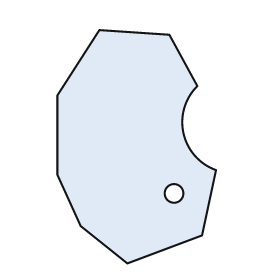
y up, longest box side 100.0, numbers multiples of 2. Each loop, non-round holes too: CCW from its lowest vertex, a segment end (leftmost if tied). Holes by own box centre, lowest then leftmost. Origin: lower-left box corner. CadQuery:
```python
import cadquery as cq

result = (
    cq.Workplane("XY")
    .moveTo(30.0, 0.0)
    .lineTo(62.0, 12.0)
    .lineTo(68.0, 40.0)
    .threePointArc((54.0, 56.0), (60.0, 76.0))
    .lineTo(48.0, 98.0)
    .lineTo(18.0, 100.0)
    .lineTo(0.0, 72.0)
    .lineTo(0.0, 38.0)
    .lineTo(10.0, 16.0)
    .close()
    .moveTo(50.0, 30.0)
    .circle(4.0)
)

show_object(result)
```